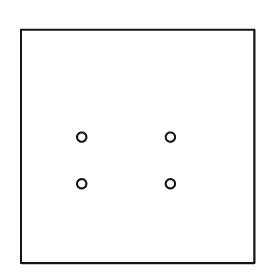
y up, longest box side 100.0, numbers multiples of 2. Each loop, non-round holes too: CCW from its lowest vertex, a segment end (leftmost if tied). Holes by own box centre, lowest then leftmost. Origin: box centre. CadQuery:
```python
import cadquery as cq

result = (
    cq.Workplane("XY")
    .moveTo(-50.0, -50.0)
    .lineTo(50.0, -50.0)
    .lineTo(50.0, 50.0)
    .lineTo(-50.0, 50.0)
    .close()
    .moveTo(-24.0, -16.0)
    .circle(2.0)
    .moveTo(14.0, -16.0)
    .circle(2.0)
    .moveTo(-24.0, 4.0)
    .circle(2.0)
    .moveTo(14.0, 4.0)
    .circle(2.0)
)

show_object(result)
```